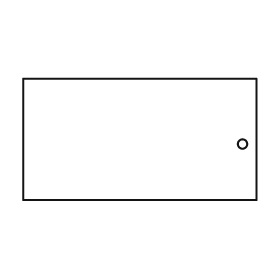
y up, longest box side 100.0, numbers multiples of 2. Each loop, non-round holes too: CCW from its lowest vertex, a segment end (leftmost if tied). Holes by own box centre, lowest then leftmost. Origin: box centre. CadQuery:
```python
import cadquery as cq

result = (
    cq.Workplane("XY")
    .moveTo(-50.0, -26.0)
    .lineTo(50.0, -26.0)
    .lineTo(50.0, 26.0)
    .lineTo(-50.0, 26.0)
    .close()
    .moveTo(44.0, -2.0)
    .circle(2.0)
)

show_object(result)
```